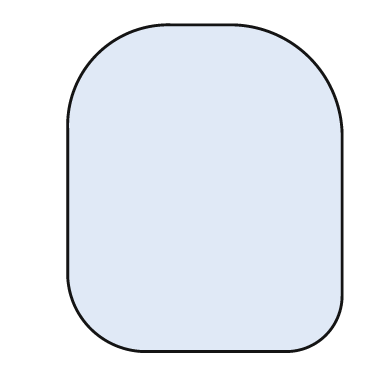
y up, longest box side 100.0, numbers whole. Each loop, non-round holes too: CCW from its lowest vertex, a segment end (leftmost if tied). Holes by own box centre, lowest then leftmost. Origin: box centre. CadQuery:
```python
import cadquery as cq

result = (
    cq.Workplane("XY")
    .moveTo(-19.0, -50.0)
    .lineTo(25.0, -50.0)
    .threePointArc((37.0, -45.0), (42.0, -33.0))
    .lineTo(42.0, 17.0)
    .threePointArc((32.0, 40.0), (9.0, 50.0))
    .lineTo(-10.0, 50.0)
    .threePointArc((-33.0, 41.0), (-42.0, 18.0))
    .lineTo(-42.0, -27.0)
    .threePointArc((-35.0, -43.0), (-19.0, -50.0))
    .close()
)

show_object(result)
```